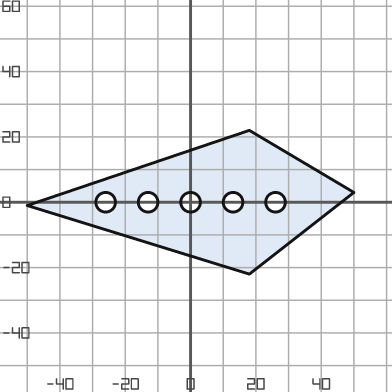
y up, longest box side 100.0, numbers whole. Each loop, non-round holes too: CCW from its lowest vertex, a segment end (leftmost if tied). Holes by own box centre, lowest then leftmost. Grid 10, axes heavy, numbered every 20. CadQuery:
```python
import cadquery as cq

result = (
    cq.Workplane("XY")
    .moveTo(18.0, -22.0)
    .lineTo(50.0, 3.0)
    .lineTo(18.0, 22.0)
    .lineTo(-50.0, -1.0)
    .close()
    .moveTo(-26.0, 0.0)
    .circle(3.0)
    .moveTo(-13.0, 0.0)
    .circle(3.0)
    .moveTo(0.0, 0.0)
    .circle(3.0)
    .moveTo(13.0, 0.0)
    .circle(3.0)
    .moveTo(26.0, 0.0)
    .circle(3.0)
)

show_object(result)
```